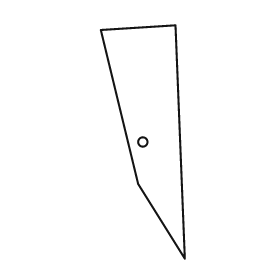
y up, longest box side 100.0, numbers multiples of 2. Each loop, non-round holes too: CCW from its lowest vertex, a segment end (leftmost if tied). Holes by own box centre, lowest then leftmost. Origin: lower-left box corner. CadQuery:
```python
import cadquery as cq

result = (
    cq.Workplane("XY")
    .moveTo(36.0, 0.0)
    .lineTo(32.0, 100.0)
    .lineTo(0.0, 98.0)
    .lineTo(16.0, 32.0)
    .close()
    .moveTo(18.0, 50.0)
    .circle(2.0)
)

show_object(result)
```